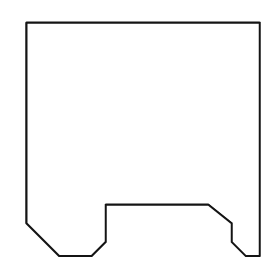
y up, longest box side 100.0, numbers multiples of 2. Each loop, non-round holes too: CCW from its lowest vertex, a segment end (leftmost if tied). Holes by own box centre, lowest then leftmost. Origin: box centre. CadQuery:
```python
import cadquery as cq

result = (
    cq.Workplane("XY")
    .moveTo(-36.0, -50.0)
    .lineTo(-22.0, -50.0)
    .lineTo(-16.0, -44.0)
    .lineTo(-16.0, -28.0)
    .lineTo(28.0, -28.0)
    .lineTo(38.0, -36.0)
    .lineTo(38.0, -44.0)
    .lineTo(44.0, -50.0)
    .lineTo(50.0, -50.0)
    .lineTo(50.0, 50.0)
    .lineTo(-50.0, 50.0)
    .lineTo(-50.0, -36.0)
    .close()
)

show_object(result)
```